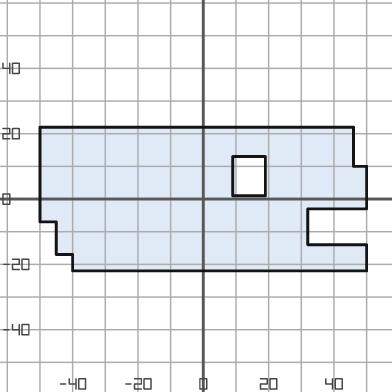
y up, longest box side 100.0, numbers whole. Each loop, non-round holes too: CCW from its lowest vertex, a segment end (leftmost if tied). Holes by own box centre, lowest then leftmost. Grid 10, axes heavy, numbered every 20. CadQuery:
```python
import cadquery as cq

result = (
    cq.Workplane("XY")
    .moveTo(-40.0, -22.0)
    .lineTo(50.0, -22.0)
    .lineTo(50.0, -14.0)
    .lineTo(32.0, -14.0)
    .lineTo(32.0, -3.0)
    .lineTo(50.0, -3.0)
    .lineTo(50.0, 10.0)
    .lineTo(46.0, 10.0)
    .lineTo(46.0, 22.0)
    .lineTo(-50.0, 22.0)
    .lineTo(-50.0, -7.0)
    .lineTo(-45.0, -7.0)
    .lineTo(-45.0, -17.0)
    .lineTo(-40.0, -17.0)
    .close()
    .moveTo(9.0, 1.0)
    .lineTo(19.0, 1.0)
    .lineTo(19.0, 13.0)
    .lineTo(9.0, 13.0)
    .close()
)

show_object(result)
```